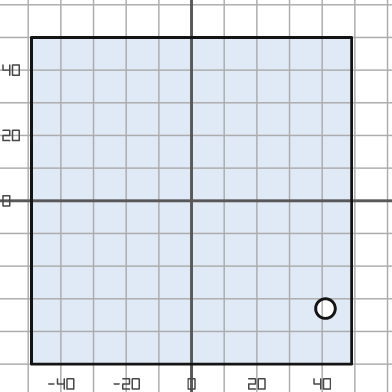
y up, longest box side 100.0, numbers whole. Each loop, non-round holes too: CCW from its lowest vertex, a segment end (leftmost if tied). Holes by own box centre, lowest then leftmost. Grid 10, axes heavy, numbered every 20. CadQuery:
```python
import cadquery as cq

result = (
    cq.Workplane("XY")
    .moveTo(-49.0, -50.0)
    .lineTo(49.0, -50.0)
    .lineTo(49.0, 50.0)
    .lineTo(-49.0, 50.0)
    .close()
    .moveTo(41.0, -33.0)
    .circle(3.0)
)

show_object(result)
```